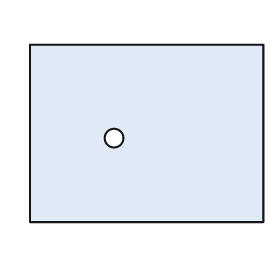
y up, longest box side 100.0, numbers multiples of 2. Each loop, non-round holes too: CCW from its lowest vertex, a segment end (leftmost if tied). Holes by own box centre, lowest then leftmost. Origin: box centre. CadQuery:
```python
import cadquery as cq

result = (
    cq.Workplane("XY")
    .moveTo(-50.0, -38.0)
    .lineTo(50.0, -38.0)
    .lineTo(50.0, 38.0)
    .lineTo(-50.0, 38.0)
    .close()
    .moveTo(-14.0, -2.0)
    .circle(4.0)
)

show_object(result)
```